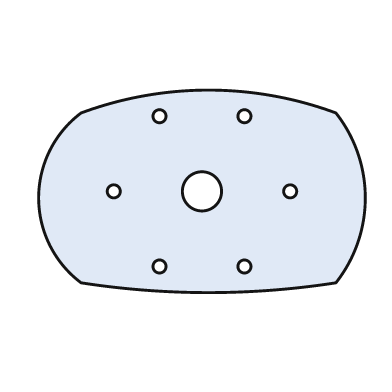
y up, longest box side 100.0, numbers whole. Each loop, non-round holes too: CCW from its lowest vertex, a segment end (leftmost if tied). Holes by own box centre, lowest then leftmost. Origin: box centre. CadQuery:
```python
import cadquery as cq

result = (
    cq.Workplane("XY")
    .moveTo(-37.0, -28.0)
    .threePointArc((2.0, -31.0), (41.0, -28.0))
    .threePointArc((50.0, -2.0), (41.0, 24.0))
    .threePointArc((2.0, 31.0), (-37.0, 24.0))
    .threePointArc((-50.0, -2.0), (-37.0, -28.0))
    .close()
    .moveTo(-13.0, -23.0)
    .circle(2.0)
    .moveTo(13.0, -23.0)
    .circle(2.0)
    .moveTo(-27.0, 0.0)
    .circle(2.0)
    .moveTo(0.0, 0.0)
    .circle(6.0)
    .moveTo(27.0, 0.0)
    .circle(2.0)
    .moveTo(-13.0, 23.0)
    .circle(2.0)
    .moveTo(13.0, 23.0)
    .circle(2.0)
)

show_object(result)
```